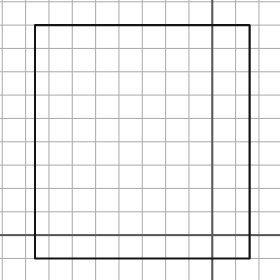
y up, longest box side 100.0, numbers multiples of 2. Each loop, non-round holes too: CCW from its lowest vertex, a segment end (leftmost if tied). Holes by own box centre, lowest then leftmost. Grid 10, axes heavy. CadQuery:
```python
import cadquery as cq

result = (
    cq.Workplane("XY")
    .moveTo(-76.0, -10.0)
    .lineTo(16.0, -10.0)
    .lineTo(16.0, 90.0)
    .lineTo(-76.0, 90.0)
    .close()
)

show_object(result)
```